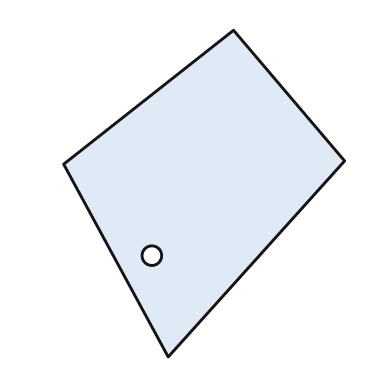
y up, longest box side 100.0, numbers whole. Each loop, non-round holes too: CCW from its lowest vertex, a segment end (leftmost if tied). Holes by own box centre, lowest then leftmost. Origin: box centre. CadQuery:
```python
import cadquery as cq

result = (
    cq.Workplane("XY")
    .moveTo(-11.0, -50.0)
    .lineTo(43.0, 10.0)
    .lineTo(9.0, 50.0)
    .lineTo(-43.0, 9.0)
    .close()
    .moveTo(-16.0, -19.0)
    .circle(3.0)
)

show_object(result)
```